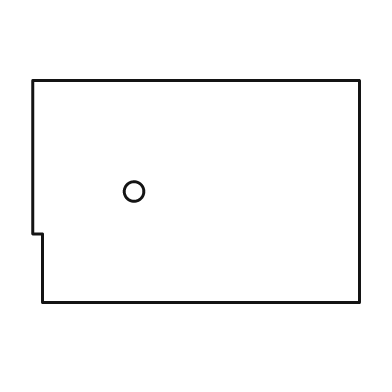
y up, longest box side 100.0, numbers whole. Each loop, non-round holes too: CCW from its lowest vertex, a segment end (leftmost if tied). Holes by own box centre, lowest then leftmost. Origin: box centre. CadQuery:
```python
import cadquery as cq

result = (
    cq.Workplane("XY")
    .moveTo(-47.0, -34.0)
    .lineTo(50.0, -34.0)
    .lineTo(50.0, 34.0)
    .lineTo(-50.0, 34.0)
    .lineTo(-50.0, -13.0)
    .lineTo(-47.0, -13.0)
    .close()
    .moveTo(-19.0, 0.0)
    .circle(3.0)
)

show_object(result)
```